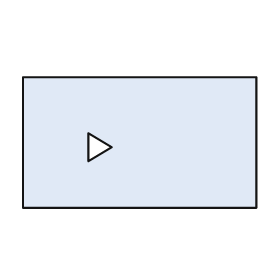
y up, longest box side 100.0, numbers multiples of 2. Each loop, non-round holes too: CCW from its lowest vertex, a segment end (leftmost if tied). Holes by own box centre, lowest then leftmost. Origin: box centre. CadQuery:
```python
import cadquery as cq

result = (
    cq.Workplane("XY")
    .moveTo(-50.0, -28.0)
    .lineTo(50.0, -28.0)
    .lineTo(50.0, 28.0)
    .lineTo(-50.0, 28.0)
    .close()
    .moveTo(-22.0, -8.0)
    .lineTo(-12.0, -2.0)
    .lineTo(-22.0, 4.0)
    .close()
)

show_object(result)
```